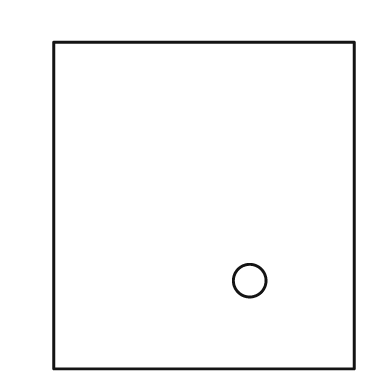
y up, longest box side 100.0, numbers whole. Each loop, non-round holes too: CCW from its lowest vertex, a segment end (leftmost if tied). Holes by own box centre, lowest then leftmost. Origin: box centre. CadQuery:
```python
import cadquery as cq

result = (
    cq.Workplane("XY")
    .moveTo(-46.0, -50.0)
    .lineTo(46.0, -50.0)
    .lineTo(46.0, 50.0)
    .lineTo(-46.0, 50.0)
    .close()
    .moveTo(14.0, -23.0)
    .circle(5.0)
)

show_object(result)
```